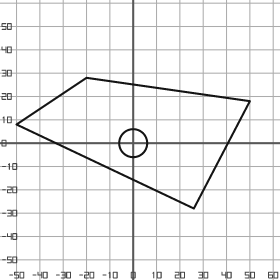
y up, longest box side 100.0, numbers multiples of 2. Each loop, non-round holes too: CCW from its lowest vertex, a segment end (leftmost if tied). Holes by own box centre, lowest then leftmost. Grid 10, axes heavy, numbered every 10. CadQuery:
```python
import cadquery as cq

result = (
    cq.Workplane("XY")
    .moveTo(26.0, -28.0)
    .lineTo(50.0, 18.0)
    .lineTo(-20.0, 28.0)
    .lineTo(-50.0, 8.0)
    .close()
    .moveTo(0.0, 0.0)
    .circle(6.0)
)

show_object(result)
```